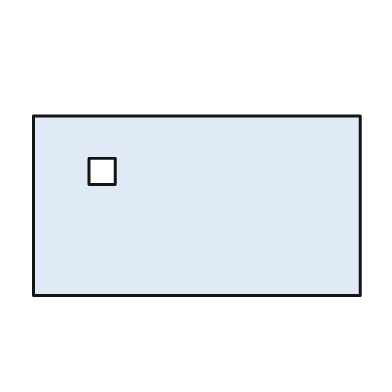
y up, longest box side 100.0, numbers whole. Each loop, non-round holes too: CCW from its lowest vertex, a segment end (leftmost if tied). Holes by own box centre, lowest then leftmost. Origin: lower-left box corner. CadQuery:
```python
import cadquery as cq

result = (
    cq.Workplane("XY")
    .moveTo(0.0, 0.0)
    .lineTo(100.0, 0.0)
    .lineTo(100.0, 55.0)
    .lineTo(0.0, 55.0)
    .close()
    .moveTo(17.0, 34.0)
    .lineTo(25.0, 34.0)
    .lineTo(25.0, 42.0)
    .lineTo(17.0, 42.0)
    .close()
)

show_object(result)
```